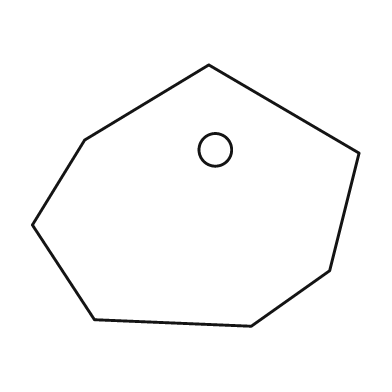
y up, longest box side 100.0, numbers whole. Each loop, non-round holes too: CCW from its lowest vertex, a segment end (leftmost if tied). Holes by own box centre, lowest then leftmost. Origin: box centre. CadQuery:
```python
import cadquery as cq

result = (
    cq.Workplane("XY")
    .moveTo(17.0, -40.0)
    .lineTo(41.0, -23.0)
    .lineTo(50.0, 13.0)
    .lineTo(4.0, 40.0)
    .lineTo(-34.0, 17.0)
    .lineTo(-50.0, -9.0)
    .lineTo(-31.0, -38.0)
    .close()
    .moveTo(6.0, 14.0)
    .circle(5.0)
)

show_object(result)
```